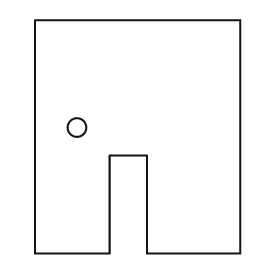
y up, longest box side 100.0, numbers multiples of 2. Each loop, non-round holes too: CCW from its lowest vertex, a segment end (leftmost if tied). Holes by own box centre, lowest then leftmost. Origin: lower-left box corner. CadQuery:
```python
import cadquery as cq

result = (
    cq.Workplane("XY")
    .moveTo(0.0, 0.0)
    .lineTo(32.0, 0.0)
    .lineTo(32.0, 42.0)
    .lineTo(48.0, 42.0)
    .lineTo(48.0, 0.0)
    .lineTo(88.0, 0.0)
    .lineTo(88.0, 100.0)
    .lineTo(0.0, 100.0)
    .close()
    .moveTo(18.0, 54.0)
    .circle(4.0)
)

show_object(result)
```